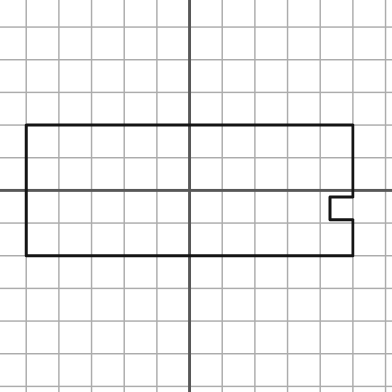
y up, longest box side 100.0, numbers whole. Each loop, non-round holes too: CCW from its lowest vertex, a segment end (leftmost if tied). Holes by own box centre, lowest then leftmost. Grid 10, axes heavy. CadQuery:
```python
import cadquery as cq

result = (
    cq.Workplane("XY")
    .moveTo(-50.0, -20.0)
    .lineTo(50.0, -20.0)
    .lineTo(50.0, -9.0)
    .lineTo(43.0, -9.0)
    .lineTo(43.0, -2.0)
    .lineTo(50.0, -2.0)
    .lineTo(50.0, 20.0)
    .lineTo(-50.0, 20.0)
    .close()
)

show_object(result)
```